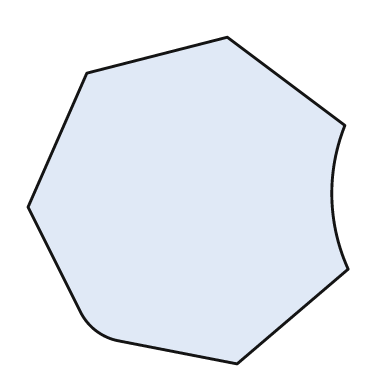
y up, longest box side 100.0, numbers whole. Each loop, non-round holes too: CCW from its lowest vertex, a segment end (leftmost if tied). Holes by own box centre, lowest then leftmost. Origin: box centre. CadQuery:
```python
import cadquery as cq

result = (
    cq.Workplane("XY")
    .moveTo(15.0, -50.0)
    .lineTo(49.0, -21.0)
    .threePointArc((44.0, 1.0), (48.0, 23.0))
    .lineTo(12.0, 50.0)
    .lineTo(-31.0, 39.0)
    .lineTo(-49.0, -2.0)
    .lineTo(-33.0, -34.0)
    .threePointArc((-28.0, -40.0), (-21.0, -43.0))
    .close()
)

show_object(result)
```